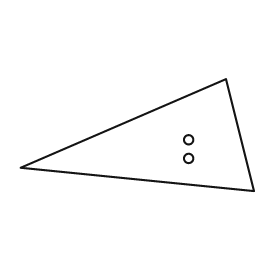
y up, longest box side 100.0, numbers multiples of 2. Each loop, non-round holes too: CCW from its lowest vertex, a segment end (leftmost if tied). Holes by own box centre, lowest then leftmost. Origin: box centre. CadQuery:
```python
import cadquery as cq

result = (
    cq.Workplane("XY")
    .moveTo(50.0, -24.0)
    .lineTo(38.0, 24.0)
    .lineTo(-50.0, -14.0)
    .close()
    .moveTo(22.0, -10.0)
    .circle(2.0)
    .moveTo(22.0, -2.0)
    .circle(2.0)
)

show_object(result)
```